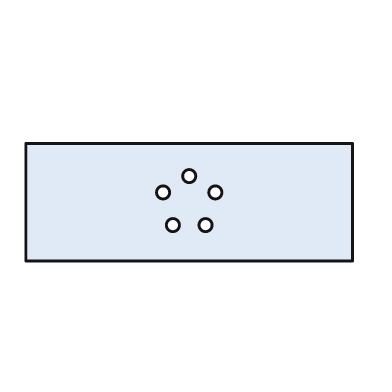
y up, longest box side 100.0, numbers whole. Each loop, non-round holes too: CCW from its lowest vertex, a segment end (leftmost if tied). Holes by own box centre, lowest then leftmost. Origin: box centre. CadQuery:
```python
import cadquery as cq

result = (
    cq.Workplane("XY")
    .moveTo(-50.0, -18.0)
    .lineTo(50.0, -18.0)
    .lineTo(50.0, 18.0)
    .lineTo(-50.0, 18.0)
    .close()
    .moveTo(-5.0, -7.0)
    .circle(2.0)
    .moveTo(5.0, -7.0)
    .circle(2.0)
    .moveTo(-8.0, 3.0)
    .circle(2.0)
    .moveTo(8.0, 3.0)
    .circle(2.0)
    .moveTo(0.0, 8.0)
    .circle(2.0)
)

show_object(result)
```